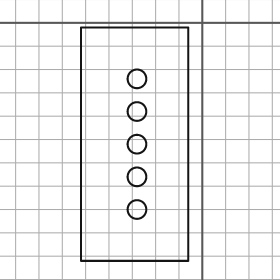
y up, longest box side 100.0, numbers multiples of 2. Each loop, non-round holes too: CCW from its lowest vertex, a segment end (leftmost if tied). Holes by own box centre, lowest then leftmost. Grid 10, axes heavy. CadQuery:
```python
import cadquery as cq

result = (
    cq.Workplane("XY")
    .moveTo(-52.0, -102.0)
    .lineTo(-6.0, -102.0)
    .lineTo(-6.0, -2.0)
    .lineTo(-52.0, -2.0)
    .close()
    .moveTo(-28.0, -80.0)
    .circle(4.0)
    .moveTo(-28.0, -66.0)
    .circle(4.0)
    .moveTo(-28.0, -52.0)
    .circle(4.0)
    .moveTo(-28.0, -38.0)
    .circle(4.0)
    .moveTo(-28.0, -24.0)
    .circle(4.0)
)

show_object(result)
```